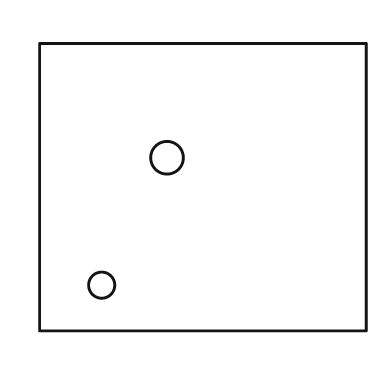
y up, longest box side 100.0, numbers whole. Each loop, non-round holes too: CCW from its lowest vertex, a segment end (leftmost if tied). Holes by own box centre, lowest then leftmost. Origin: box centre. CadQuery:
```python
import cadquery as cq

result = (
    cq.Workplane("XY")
    .moveTo(-50.0, -44.0)
    .lineTo(50.0, -44.0)
    .lineTo(50.0, 44.0)
    .lineTo(-50.0, 44.0)
    .close()
    .moveTo(-31.0, -30.0)
    .circle(4.0)
    .moveTo(-11.0, 9.0)
    .circle(5.0)
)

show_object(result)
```